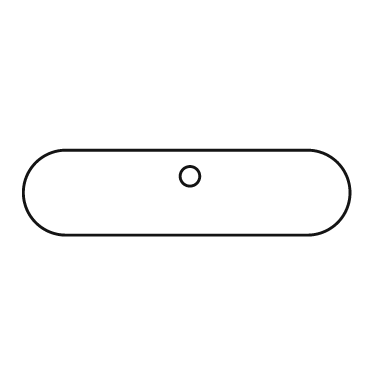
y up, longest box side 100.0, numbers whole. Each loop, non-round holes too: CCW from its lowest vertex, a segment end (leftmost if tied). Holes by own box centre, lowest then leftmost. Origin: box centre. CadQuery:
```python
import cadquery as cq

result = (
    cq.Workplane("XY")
    .moveTo(-37.0, -13.0)
    .lineTo(37.0, -13.0)
    .threePointArc((50.0, 0.0), (37.0, 13.0))
    .lineTo(-37.0, 13.0)
    .threePointArc((-50.0, 0.0), (-37.0, -13.0))
    .close()
    .moveTo(1.0, 5.0)
    .circle(3.0)
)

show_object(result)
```